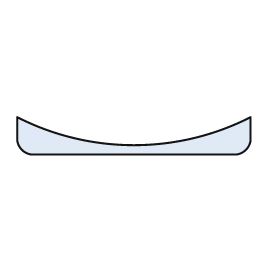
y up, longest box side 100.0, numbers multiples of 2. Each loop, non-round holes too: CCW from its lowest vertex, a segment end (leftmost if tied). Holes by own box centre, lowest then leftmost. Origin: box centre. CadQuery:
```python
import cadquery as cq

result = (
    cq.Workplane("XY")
    .moveTo(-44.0, -8.0)
    .lineTo(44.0, -8.0)
    .threePointArc((48.0, -6.0), (50.0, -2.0))
    .lineTo(50.0, 8.0)
    .threePointArc((0.0, -4.0), (-50.0, 8.0))
    .lineTo(-50.0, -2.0)
    .threePointArc((-48.0, -6.0), (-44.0, -8.0))
    .close()
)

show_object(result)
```